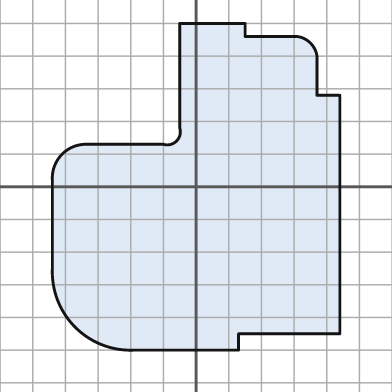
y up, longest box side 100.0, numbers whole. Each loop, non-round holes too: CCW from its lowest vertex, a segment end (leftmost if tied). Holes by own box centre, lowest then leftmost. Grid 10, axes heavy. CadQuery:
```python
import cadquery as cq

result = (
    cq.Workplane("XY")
    .moveTo(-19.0, -50.0)
    .lineTo(13.0, -50.0)
    .lineTo(13.0, -45.0)
    .lineTo(44.0, -45.0)
    .lineTo(44.0, 28.0)
    .lineTo(37.0, 28.0)
    .lineTo(37.0, 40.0)
    .threePointArc((35.0, 44.0), (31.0, 46.0))
    .lineTo(15.0, 46.0)
    .lineTo(15.0, 50.0)
    .lineTo(-5.0, 50.0)
    .lineTo(-5.0, 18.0)
    .threePointArc((-6.0, 14.0), (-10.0, 13.0))
    .lineTo(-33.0, 13.0)
    .threePointArc((-41.0, 10.0), (-44.0, 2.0))
    .lineTo(-44.0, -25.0)
    .threePointArc((-37.0, -43.0), (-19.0, -50.0))
    .close()
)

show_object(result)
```